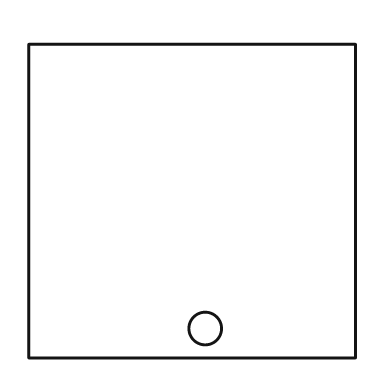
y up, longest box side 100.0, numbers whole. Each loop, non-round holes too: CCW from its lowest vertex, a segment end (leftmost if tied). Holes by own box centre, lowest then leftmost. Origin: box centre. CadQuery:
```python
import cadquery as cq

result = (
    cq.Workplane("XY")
    .moveTo(-50.0, -48.0)
    .lineTo(50.0, -48.0)
    .lineTo(50.0, 48.0)
    .lineTo(-50.0, 48.0)
    .close()
    .moveTo(4.0, -39.0)
    .circle(5.0)
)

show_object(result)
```